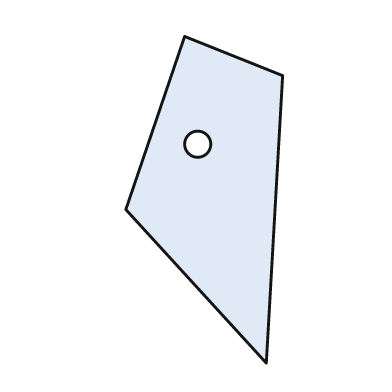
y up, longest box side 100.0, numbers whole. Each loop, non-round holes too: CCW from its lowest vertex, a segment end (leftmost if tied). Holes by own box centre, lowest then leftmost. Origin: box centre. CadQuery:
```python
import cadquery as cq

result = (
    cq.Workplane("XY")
    .moveTo(19.0, -50.0)
    .lineTo(24.0, 38.0)
    .lineTo(-6.0, 50.0)
    .lineTo(-24.0, -3.0)
    .close()
    .moveTo(-2.0, 17.0)
    .circle(4.0)
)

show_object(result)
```